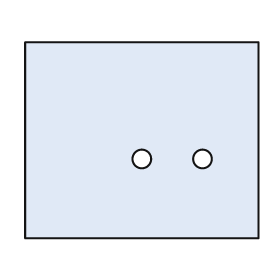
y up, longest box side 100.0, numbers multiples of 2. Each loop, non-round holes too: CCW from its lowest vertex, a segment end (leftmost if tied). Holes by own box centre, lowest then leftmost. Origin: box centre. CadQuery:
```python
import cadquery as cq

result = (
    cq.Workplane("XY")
    .moveTo(-50.0, -42.0)
    .lineTo(50.0, -42.0)
    .lineTo(50.0, 42.0)
    .lineTo(-50.0, 42.0)
    .close()
    .moveTo(0.0, -8.0)
    .circle(4.0)
    .moveTo(26.0, -8.0)
    .circle(4.0)
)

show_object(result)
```